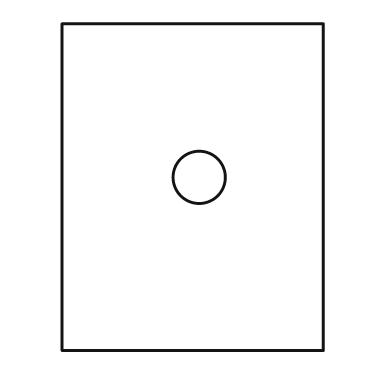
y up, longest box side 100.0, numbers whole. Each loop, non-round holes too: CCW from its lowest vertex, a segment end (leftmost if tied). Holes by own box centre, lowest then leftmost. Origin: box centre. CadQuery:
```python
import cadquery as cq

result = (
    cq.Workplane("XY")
    .moveTo(-40.0, -50.0)
    .lineTo(40.0, -50.0)
    .lineTo(40.0, 50.0)
    .lineTo(-40.0, 50.0)
    .close()
    .moveTo(2.0, 3.0)
    .circle(8.0)
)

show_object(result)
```